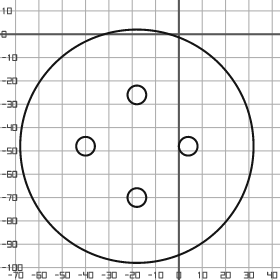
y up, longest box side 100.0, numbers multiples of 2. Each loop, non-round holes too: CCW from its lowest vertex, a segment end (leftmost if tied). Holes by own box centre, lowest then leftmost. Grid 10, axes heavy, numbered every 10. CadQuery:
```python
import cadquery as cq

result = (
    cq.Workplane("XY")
    .moveTo(-18.0, -48.0)
    .circle(50.0)
    .moveTo(-18.0, -70.0)
    .circle(4.0)
    .moveTo(-40.0, -48.0)
    .circle(4.0)
    .moveTo(4.0, -48.0)
    .circle(4.0)
    .moveTo(-18.0, -26.0)
    .circle(4.0)
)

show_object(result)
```